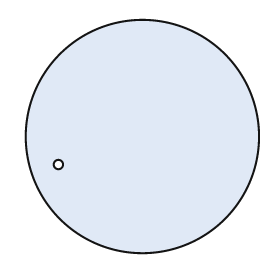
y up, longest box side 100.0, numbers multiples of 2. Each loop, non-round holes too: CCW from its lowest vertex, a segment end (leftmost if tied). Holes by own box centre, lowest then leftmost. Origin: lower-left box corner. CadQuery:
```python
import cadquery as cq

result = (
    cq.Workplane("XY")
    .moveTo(50.0, 50.0)
    .circle(50.0)
    .moveTo(14.0, 38.0)
    .circle(2.0)
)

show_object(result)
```